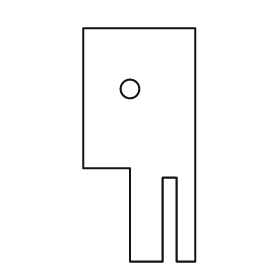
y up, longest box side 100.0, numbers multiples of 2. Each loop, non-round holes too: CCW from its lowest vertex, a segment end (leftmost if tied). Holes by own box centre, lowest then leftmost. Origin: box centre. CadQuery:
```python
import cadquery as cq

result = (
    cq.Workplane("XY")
    .moveTo(-4.0, -50.0)
    .lineTo(10.0, -50.0)
    .lineTo(10.0, -14.0)
    .lineTo(16.0, -14.0)
    .lineTo(16.0, -50.0)
    .lineTo(24.0, -50.0)
    .lineTo(24.0, 50.0)
    .lineTo(-24.0, 50.0)
    .lineTo(-24.0, -10.0)
    .lineTo(-4.0, -10.0)
    .close()
    .moveTo(-4.0, 24.0)
    .circle(4.0)
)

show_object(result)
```